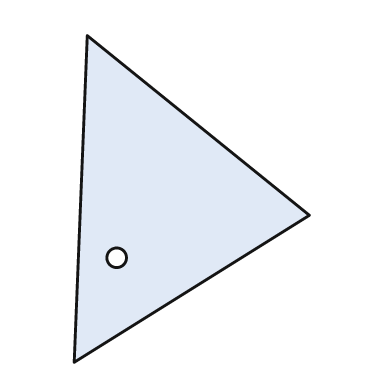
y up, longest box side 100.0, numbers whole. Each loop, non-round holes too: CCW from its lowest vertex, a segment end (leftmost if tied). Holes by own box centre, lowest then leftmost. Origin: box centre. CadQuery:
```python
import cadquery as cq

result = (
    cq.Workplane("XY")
    .moveTo(-36.0, -50.0)
    .lineTo(36.0, -5.0)
    .lineTo(-32.0, 50.0)
    .close()
    .moveTo(-23.0, -18.0)
    .circle(3.0)
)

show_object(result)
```